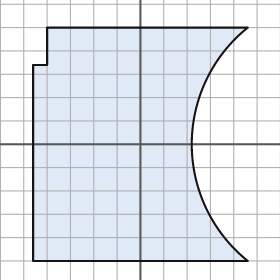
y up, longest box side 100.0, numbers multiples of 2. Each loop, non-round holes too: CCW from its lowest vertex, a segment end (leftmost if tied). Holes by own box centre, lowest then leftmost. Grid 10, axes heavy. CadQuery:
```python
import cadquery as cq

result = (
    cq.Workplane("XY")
    .moveTo(-46.0, -50.0)
    .lineTo(46.0, -50.0)
    .threePointArc((22.0, 0.0), (46.0, 50.0))
    .lineTo(-40.0, 50.0)
    .lineTo(-40.0, 34.0)
    .lineTo(-46.0, 34.0)
    .close()
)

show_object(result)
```